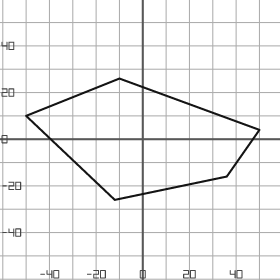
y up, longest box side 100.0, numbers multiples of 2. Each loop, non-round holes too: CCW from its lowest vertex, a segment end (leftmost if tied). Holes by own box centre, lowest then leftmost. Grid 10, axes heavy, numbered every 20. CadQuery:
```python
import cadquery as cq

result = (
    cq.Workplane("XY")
    .moveTo(-12.0, -26.0)
    .lineTo(36.0, -16.0)
    .lineTo(50.0, 4.0)
    .lineTo(-10.0, 26.0)
    .lineTo(-50.0, 10.0)
    .close()
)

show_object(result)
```